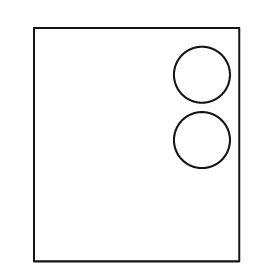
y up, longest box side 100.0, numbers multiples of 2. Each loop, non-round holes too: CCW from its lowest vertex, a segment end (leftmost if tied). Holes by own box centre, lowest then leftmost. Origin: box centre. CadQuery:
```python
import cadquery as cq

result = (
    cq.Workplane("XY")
    .moveTo(-44.0, -50.0)
    .lineTo(44.0, -50.0)
    .lineTo(44.0, 50.0)
    .lineTo(-44.0, 50.0)
    .close()
    .moveTo(28.0, 2.0)
    .circle(12.0)
    .moveTo(28.0, 30.0)
    .circle(12.0)
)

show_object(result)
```